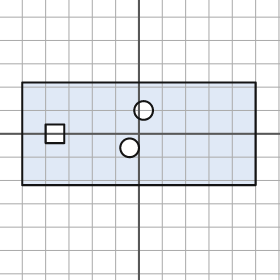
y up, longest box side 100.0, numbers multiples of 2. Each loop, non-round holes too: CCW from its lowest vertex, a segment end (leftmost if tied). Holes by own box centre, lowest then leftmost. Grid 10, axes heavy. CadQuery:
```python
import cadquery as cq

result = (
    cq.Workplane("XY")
    .moveTo(-50.0, -22.0)
    .lineTo(50.0, -22.0)
    .lineTo(50.0, 22.0)
    .lineTo(-50.0, 22.0)
    .close()
    .moveTo(-4.0, -6.0)
    .circle(4.0)
    .moveTo(-40.0, -4.0)
    .lineTo(-32.0, -4.0)
    .lineTo(-32.0, 4.0)
    .lineTo(-40.0, 4.0)
    .close()
    .moveTo(2.0, 10.0)
    .circle(4.0)
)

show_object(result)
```